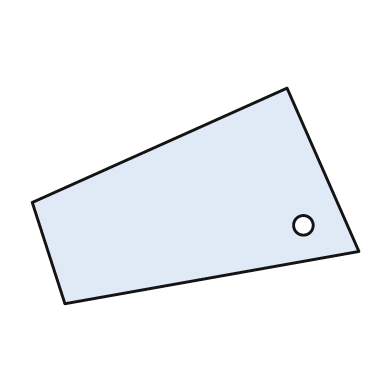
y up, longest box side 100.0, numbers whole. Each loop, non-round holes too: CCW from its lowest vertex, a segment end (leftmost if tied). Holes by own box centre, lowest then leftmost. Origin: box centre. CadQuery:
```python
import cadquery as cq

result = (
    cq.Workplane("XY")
    .moveTo(-40.0, -33.0)
    .lineTo(50.0, -17.0)
    .lineTo(28.0, 33.0)
    .lineTo(-50.0, -2.0)
    .close()
    .moveTo(33.0, -9.0)
    .circle(3.0)
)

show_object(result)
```